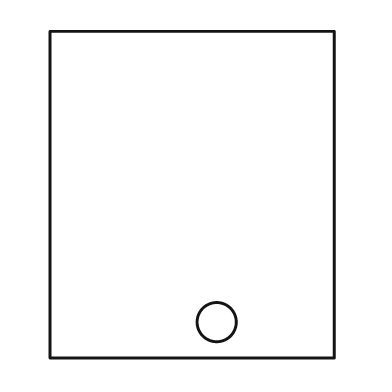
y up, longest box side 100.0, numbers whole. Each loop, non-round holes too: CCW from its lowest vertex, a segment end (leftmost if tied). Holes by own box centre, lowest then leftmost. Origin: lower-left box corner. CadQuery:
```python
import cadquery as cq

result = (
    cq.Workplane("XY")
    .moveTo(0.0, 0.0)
    .lineTo(87.0, 0.0)
    .lineTo(87.0, 100.0)
    .lineTo(0.0, 100.0)
    .close()
    .moveTo(51.0, 11.0)
    .circle(6.0)
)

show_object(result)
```